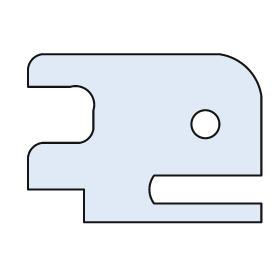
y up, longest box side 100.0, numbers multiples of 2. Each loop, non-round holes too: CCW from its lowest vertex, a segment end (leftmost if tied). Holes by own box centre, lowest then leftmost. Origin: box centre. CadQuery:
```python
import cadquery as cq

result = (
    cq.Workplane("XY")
    .moveTo(-26.0, -36.0)
    .lineTo(50.0, -36.0)
    .lineTo(50.0, -28.0)
    .lineTo(4.0, -28.0)
    .threePointArc((2.0, -22.0), (4.0, -16.0))
    .lineTo(50.0, -16.0)
    .lineTo(50.0, 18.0)
    .threePointArc((44.0, 30.0), (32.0, 36.0))
    .lineTo(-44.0, 36.0)
    .threePointArc((-48.0, 34.0), (-50.0, 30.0))
    .lineTo(-50.0, 22.0)
    .lineTo(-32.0, 22.0)
    .threePointArc((-24.0, 20.0), (-22.0, 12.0))
    .lineTo(-22.0, 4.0)
    .threePointArc((-24.0, 0.0), (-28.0, -2.0))
    .lineTo(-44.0, -2.0)
    .threePointArc((-48.0, -4.0), (-50.0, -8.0))
    .lineTo(-50.0, -22.0)
    .lineTo(-26.0, -22.0)
    .close()
    .moveTo(26.0, 6.0)
    .circle(6.0)
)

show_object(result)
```